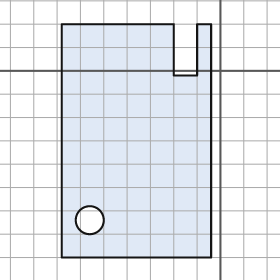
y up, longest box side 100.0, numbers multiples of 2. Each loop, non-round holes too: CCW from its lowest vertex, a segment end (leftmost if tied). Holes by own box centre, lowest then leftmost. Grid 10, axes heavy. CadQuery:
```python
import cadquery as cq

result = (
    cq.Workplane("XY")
    .moveTo(-68.0, -80.0)
    .lineTo(-4.0, -80.0)
    .lineTo(-4.0, 20.0)
    .lineTo(-10.0, 20.0)
    .lineTo(-10.0, -2.0)
    .lineTo(-20.0, -2.0)
    .lineTo(-20.0, 20.0)
    .lineTo(-68.0, 20.0)
    .close()
    .moveTo(-56.0, -64.0)
    .circle(6.0)
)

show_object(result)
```